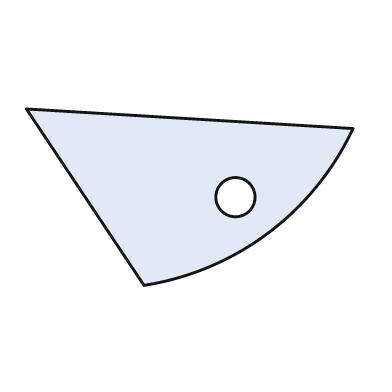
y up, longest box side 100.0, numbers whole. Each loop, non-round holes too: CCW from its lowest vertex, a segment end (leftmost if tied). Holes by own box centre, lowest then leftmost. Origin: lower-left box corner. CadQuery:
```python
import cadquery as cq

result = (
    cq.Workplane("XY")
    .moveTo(36.0, 0.0)
    .threePointArc((74.0, 16.0), (100.0, 48.0))
    .lineTo(0.0, 54.0)
    .close()
    .moveTo(64.0, 27.0)
    .circle(6.0)
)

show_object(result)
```